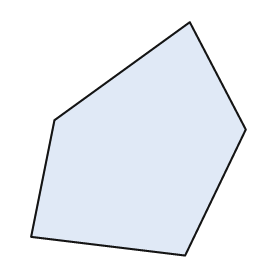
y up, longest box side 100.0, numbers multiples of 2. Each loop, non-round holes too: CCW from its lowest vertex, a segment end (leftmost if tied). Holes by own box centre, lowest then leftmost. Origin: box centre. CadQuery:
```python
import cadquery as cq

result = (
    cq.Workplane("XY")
    .moveTo(20.0, -50.0)
    .lineTo(46.0, 4.0)
    .lineTo(22.0, 50.0)
    .lineTo(-36.0, 8.0)
    .lineTo(-46.0, -42.0)
    .close()
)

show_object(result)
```